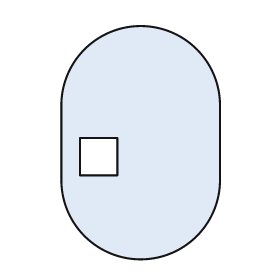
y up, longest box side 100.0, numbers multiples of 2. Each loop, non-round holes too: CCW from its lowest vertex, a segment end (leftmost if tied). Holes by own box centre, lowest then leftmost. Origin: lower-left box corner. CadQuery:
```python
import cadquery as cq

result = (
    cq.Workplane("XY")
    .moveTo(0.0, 34.0)
    .threePointArc((34.0, 0.0), (68.0, 34.0))
    .lineTo(68.0, 66.0)
    .threePointArc((34.0, 100.0), (0.0, 66.0))
    .close()
    .moveTo(8.0, 36.0)
    .lineTo(24.0, 36.0)
    .lineTo(24.0, 52.0)
    .lineTo(8.0, 52.0)
    .close()
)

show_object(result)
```